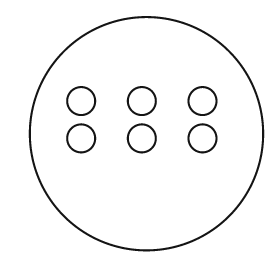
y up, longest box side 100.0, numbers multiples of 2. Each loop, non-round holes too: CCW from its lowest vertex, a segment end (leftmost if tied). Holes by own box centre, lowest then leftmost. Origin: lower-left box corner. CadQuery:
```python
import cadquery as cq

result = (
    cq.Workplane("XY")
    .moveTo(50.0, 50.0)
    .circle(50.0)
    .moveTo(22.0, 48.0)
    .circle(6.0)
    .moveTo(48.0, 48.0)
    .circle(6.0)
    .moveTo(74.0, 48.0)
    .circle(6.0)
    .moveTo(22.0, 64.0)
    .circle(6.0)
    .moveTo(48.0, 64.0)
    .circle(6.0)
    .moveTo(74.0, 64.0)
    .circle(6.0)
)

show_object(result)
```